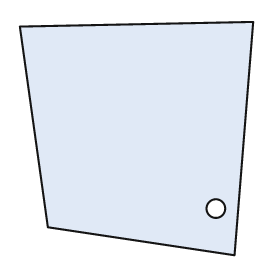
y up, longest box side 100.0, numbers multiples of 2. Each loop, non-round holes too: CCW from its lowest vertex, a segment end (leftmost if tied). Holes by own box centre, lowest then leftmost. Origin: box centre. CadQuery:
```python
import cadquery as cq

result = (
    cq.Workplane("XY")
    .moveTo(42.0, -50.0)
    .lineTo(50.0, 50.0)
    .lineTo(-50.0, 48.0)
    .lineTo(-38.0, -38.0)
    .close()
    .moveTo(34.0, -30.0)
    .circle(4.0)
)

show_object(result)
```